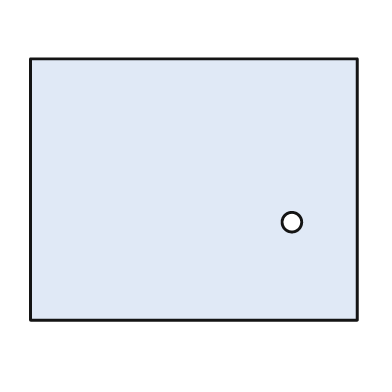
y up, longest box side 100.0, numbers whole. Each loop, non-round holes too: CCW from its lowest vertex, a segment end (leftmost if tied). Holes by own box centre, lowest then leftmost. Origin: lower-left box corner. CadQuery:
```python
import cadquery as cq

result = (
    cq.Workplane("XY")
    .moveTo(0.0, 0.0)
    .lineTo(100.0, 0.0)
    .lineTo(100.0, 80.0)
    .lineTo(0.0, 80.0)
    .close()
    .moveTo(80.0, 30.0)
    .circle(3.0)
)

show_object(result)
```